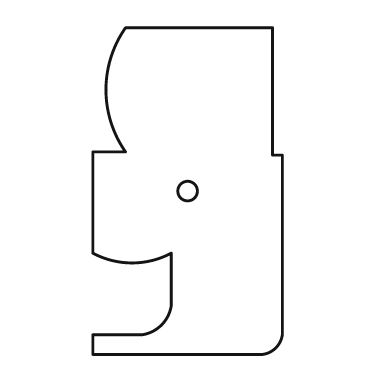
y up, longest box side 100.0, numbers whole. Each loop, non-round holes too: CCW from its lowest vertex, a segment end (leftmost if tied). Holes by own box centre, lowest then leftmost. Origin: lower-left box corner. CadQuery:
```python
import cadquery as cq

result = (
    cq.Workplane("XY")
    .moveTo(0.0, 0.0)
    .lineTo(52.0, 0.0)
    .threePointArc((56.0, 2.0), (58.0, 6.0))
    .lineTo(58.0, 61.0)
    .lineTo(55.0, 61.0)
    .lineTo(55.0, 100.0)
    .lineTo(10.0, 100.0)
    .threePointArc((4.0, 81.0), (10.0, 62.0))
    .lineTo(0.0, 62.0)
    .lineTo(0.0, 31.0)
    .threePointArc((12.0, 28.0), (24.0, 31.0))
    .lineTo(24.0, 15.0)
    .threePointArc((21.0, 9.0), (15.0, 6.0))
    .lineTo(0.0, 6.0)
    .close()
    .moveTo(29.0, 50.0)
    .circle(3.0)
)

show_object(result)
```